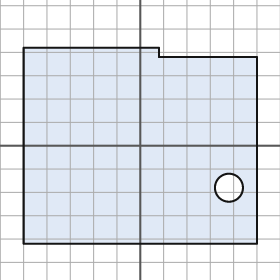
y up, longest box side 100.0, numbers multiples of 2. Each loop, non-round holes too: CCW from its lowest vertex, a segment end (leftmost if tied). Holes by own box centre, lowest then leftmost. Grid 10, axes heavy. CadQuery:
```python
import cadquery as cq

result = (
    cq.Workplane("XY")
    .moveTo(-50.0, -42.0)
    .lineTo(50.0, -42.0)
    .lineTo(50.0, 38.0)
    .lineTo(8.0, 38.0)
    .lineTo(8.0, 42.0)
    .lineTo(-50.0, 42.0)
    .close()
    .moveTo(38.0, -18.0)
    .circle(6.0)
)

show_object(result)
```